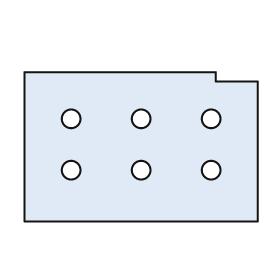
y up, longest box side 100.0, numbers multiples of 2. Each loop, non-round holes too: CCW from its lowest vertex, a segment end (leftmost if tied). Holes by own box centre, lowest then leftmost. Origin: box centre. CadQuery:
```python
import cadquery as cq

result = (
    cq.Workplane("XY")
    .moveTo(-50.0, -32.0)
    .lineTo(50.0, -32.0)
    .lineTo(50.0, 28.0)
    .lineTo(32.0, 28.0)
    .lineTo(32.0, 32.0)
    .lineTo(-50.0, 32.0)
    .close()
    .moveTo(-30.0, -10.0)
    .circle(4.0)
    .moveTo(0.0, -10.0)
    .circle(4.0)
    .moveTo(30.0, -10.0)
    .circle(4.0)
    .moveTo(-30.0, 12.0)
    .circle(4.0)
    .moveTo(0.0, 12.0)
    .circle(4.0)
    .moveTo(30.0, 12.0)
    .circle(4.0)
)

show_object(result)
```